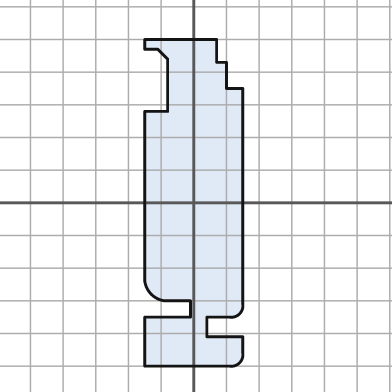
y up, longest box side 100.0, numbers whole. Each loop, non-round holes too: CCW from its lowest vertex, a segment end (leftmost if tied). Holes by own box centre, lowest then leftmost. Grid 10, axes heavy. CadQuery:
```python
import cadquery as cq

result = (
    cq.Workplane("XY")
    .moveTo(-15.0, -50.0)
    .lineTo(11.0, -50.0)
    .threePointArc((14.0, -49.0), (15.0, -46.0))
    .lineTo(15.0, -41.0)
    .lineTo(4.0, -41.0)
    .lineTo(4.0, -35.0)
    .lineTo(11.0, -35.0)
    .threePointArc((14.0, -34.0), (15.0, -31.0))
    .lineTo(15.0, 35.0)
    .lineTo(10.0, 35.0)
    .lineTo(10.0, 43.0)
    .lineTo(7.0, 43.0)
    .lineTo(7.0, 50.0)
    .lineTo(-15.0, 50.0)
    .lineTo(-15.0, 47.0)
    .lineTo(-11.0, 47.0)
    .lineTo(-8.0, 44.0)
    .lineTo(-8.0, 28.0)
    .lineTo(-15.0, 28.0)
    .lineTo(-15.0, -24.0)
    .threePointArc((-13.0, -28.0), (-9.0, -30.0))
    .lineTo(-1.0, -30.0)
    .lineTo(-1.0, -35.0)
    .lineTo(-15.0, -35.0)
    .close()
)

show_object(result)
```